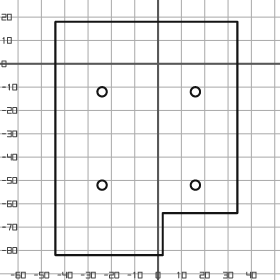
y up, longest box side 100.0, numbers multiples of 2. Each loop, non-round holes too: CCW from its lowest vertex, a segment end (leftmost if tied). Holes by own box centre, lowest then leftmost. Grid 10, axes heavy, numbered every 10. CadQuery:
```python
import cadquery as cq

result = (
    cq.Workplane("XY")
    .moveTo(-44.0, -82.0)
    .lineTo(2.0, -82.0)
    .lineTo(2.0, -64.0)
    .lineTo(34.0, -64.0)
    .lineTo(34.0, 18.0)
    .lineTo(-44.0, 18.0)
    .close()
    .moveTo(-24.0, -52.0)
    .circle(2.0)
    .moveTo(16.0, -52.0)
    .circle(2.0)
    .moveTo(-24.0, -12.0)
    .circle(2.0)
    .moveTo(16.0, -12.0)
    .circle(2.0)
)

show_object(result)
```